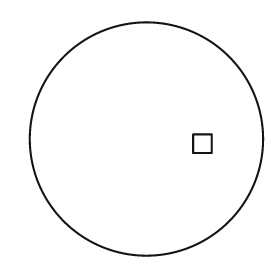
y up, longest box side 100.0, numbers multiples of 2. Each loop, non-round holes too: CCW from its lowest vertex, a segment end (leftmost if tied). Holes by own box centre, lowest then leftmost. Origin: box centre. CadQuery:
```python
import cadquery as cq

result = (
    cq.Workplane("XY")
    .moveTo(0.0, 0.0)
    .circle(50.0)
    .moveTo(20.0, -6.0)
    .lineTo(28.0, -6.0)
    .lineTo(28.0, 2.0)
    .lineTo(20.0, 2.0)
    .close()
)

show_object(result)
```